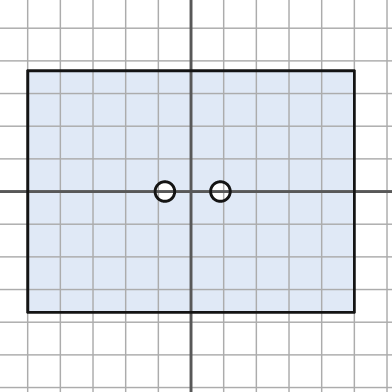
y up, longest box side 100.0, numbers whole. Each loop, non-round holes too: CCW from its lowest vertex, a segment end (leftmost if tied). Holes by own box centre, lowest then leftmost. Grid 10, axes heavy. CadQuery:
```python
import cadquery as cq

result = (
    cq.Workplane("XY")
    .moveTo(-50.0, -37.0)
    .lineTo(50.0, -37.0)
    .lineTo(50.0, 37.0)
    .lineTo(-50.0, 37.0)
    .close()
    .moveTo(-8.0, 0.0)
    .circle(3.0)
    .moveTo(9.0, 0.0)
    .circle(3.0)
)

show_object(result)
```